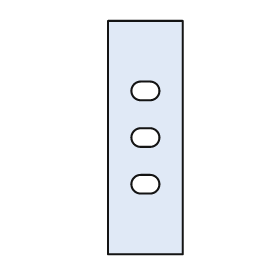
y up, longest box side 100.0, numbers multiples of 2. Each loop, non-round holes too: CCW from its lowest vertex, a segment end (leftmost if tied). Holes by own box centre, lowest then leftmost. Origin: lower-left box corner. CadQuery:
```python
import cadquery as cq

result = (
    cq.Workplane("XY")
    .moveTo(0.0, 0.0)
    .lineTo(32.0, 0.0)
    .lineTo(32.0, 100.0)
    .lineTo(0.0, 100.0)
    .close()
    .moveTo(14.0, 26.0)
    .lineTo(18.0, 26.0)
    .threePointArc((22.0, 30.0), (18.0, 34.0))
    .lineTo(14.0, 34.0)
    .threePointArc((10.0, 30.0), (14.0, 26.0))
    .close()
    .moveTo(14.0, 46.0)
    .lineTo(18.0, 46.0)
    .threePointArc((22.0, 50.0), (18.0, 54.0))
    .lineTo(14.0, 54.0)
    .threePointArc((10.0, 50.0), (14.0, 46.0))
    .close()
    .moveTo(14.0, 66.0)
    .lineTo(18.0, 66.0)
    .threePointArc((22.0, 70.0), (18.0, 74.0))
    .lineTo(14.0, 74.0)
    .threePointArc((10.0, 70.0), (14.0, 66.0))
    .close()
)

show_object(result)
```